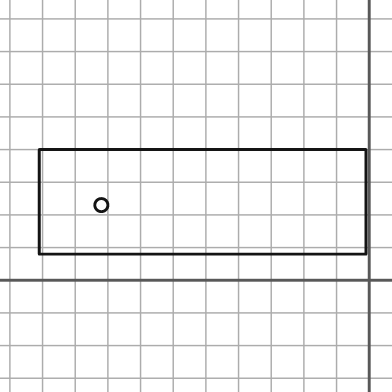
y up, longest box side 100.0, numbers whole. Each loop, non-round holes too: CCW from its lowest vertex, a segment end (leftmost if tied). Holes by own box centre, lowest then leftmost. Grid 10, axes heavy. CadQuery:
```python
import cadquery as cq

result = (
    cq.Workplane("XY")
    .moveTo(-101.0, 8.0)
    .lineTo(-1.0, 8.0)
    .lineTo(-1.0, 40.0)
    .lineTo(-101.0, 40.0)
    .close()
    .moveTo(-82.0, 23.0)
    .circle(2.0)
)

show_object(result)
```